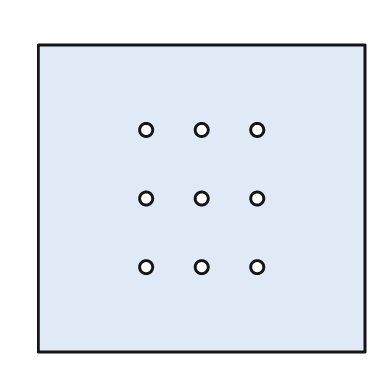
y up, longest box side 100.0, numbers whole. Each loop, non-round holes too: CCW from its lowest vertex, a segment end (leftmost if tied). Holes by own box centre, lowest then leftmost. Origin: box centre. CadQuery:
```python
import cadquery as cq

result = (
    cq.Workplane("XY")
    .moveTo(-50.0, -47.0)
    .lineTo(50.0, -47.0)
    .lineTo(50.0, 47.0)
    .lineTo(-50.0, 47.0)
    .close()
    .moveTo(-17.0, -21.0)
    .circle(2.0)
    .moveTo(0.0, -21.0)
    .circle(2.0)
    .moveTo(17.0, -21.0)
    .circle(2.0)
    .moveTo(-17.0, 0.0)
    .circle(2.0)
    .moveTo(0.0, 0.0)
    .circle(2.0)
    .moveTo(17.0, 0.0)
    .circle(2.0)
    .moveTo(-17.0, 21.0)
    .circle(2.0)
    .moveTo(0.0, 21.0)
    .circle(2.0)
    .moveTo(17.0, 21.0)
    .circle(2.0)
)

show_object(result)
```